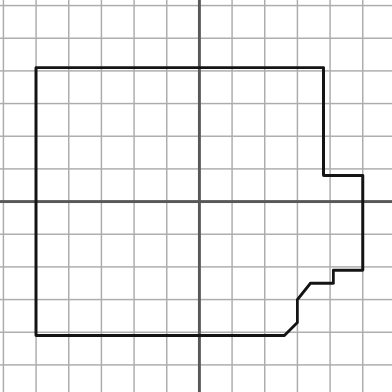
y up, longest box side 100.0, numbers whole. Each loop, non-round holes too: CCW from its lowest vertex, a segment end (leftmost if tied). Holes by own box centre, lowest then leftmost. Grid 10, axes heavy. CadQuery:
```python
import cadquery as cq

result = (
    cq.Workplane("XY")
    .moveTo(-50.0, -41.0)
    .lineTo(26.0, -41.0)
    .lineTo(30.0, -37.0)
    .lineTo(30.0, -30.0)
    .lineTo(34.0, -25.0)
    .lineTo(41.0, -25.0)
    .lineTo(41.0, -21.0)
    .lineTo(50.0, -21.0)
    .lineTo(50.0, 8.0)
    .lineTo(38.0, 8.0)
    .lineTo(38.0, 41.0)
    .lineTo(-50.0, 41.0)
    .close()
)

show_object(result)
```